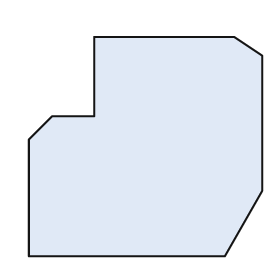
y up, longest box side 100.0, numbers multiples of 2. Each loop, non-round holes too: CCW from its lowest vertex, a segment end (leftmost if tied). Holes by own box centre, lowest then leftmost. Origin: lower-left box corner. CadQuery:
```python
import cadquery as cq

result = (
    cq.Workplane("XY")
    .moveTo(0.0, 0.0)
    .lineTo(84.0, 0.0)
    .lineTo(100.0, 28.0)
    .lineTo(100.0, 86.0)
    .lineTo(88.0, 94.0)
    .lineTo(28.0, 94.0)
    .lineTo(28.0, 60.0)
    .lineTo(10.0, 60.0)
    .lineTo(0.0, 50.0)
    .close()
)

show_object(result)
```